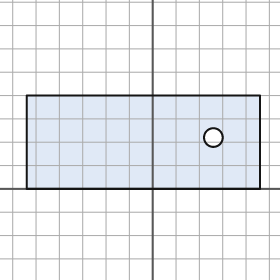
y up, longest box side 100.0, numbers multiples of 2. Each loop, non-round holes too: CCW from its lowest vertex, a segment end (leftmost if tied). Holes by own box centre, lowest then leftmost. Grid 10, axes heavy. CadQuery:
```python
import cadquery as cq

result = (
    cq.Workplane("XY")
    .moveTo(-54.0, 0.0)
    .lineTo(46.0, 0.0)
    .lineTo(46.0, 40.0)
    .lineTo(-54.0, 40.0)
    .close()
    .moveTo(26.0, 22.0)
    .circle(4.0)
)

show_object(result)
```